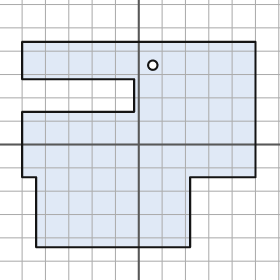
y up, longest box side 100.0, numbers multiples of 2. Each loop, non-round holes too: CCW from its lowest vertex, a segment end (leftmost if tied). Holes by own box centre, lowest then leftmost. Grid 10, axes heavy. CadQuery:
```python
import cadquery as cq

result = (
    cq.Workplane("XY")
    .moveTo(-44.0, -44.0)
    .lineTo(22.0, -44.0)
    .lineTo(22.0, -14.0)
    .lineTo(50.0, -14.0)
    .lineTo(50.0, 44.0)
    .lineTo(-50.0, 44.0)
    .lineTo(-50.0, 28.0)
    .lineTo(-2.0, 28.0)
    .lineTo(-2.0, 14.0)
    .lineTo(-50.0, 14.0)
    .lineTo(-50.0, -14.0)
    .lineTo(-44.0, -14.0)
    .close()
    .moveTo(6.0, 34.0)
    .circle(2.0)
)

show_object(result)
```